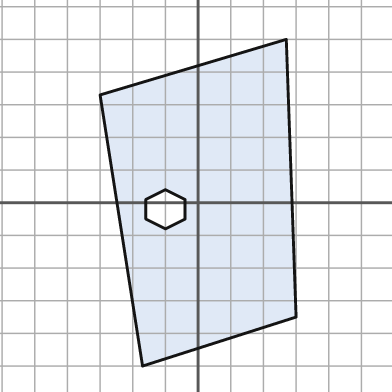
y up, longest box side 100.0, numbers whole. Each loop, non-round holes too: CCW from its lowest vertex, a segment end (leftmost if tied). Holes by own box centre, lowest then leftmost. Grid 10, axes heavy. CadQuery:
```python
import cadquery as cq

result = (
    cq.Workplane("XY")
    .moveTo(-17.0, -50.0)
    .lineTo(30.0, -35.0)
    .lineTo(27.0, 50.0)
    .lineTo(-30.0, 33.0)
    .close()
    .moveTo(-10.0, -8.0)
    .lineTo(-4.0, -5.0)
    .lineTo(-4.0, 1.0)
    .lineTo(-10.0, 4.0)
    .lineTo(-16.0, 1.0)
    .lineTo(-16.0, -5.0)
    .close()
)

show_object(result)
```